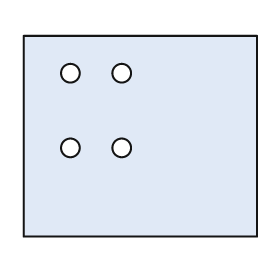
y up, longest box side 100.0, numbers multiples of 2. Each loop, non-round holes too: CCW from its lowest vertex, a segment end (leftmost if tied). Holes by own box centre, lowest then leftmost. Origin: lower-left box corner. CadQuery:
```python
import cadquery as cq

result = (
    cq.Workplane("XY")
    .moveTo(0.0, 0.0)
    .lineTo(100.0, 0.0)
    .lineTo(100.0, 86.0)
    .lineTo(0.0, 86.0)
    .close()
    .moveTo(20.0, 38.0)
    .circle(4.0)
    .moveTo(42.0, 38.0)
    .circle(4.0)
    .moveTo(20.0, 70.0)
    .circle(4.0)
    .moveTo(42.0, 70.0)
    .circle(4.0)
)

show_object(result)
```